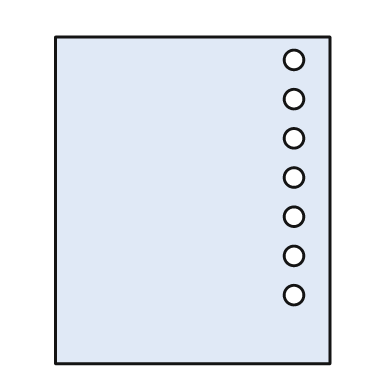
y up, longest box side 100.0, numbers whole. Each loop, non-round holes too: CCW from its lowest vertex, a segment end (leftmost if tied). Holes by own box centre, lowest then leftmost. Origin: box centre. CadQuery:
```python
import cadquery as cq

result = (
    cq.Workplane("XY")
    .moveTo(-42.0, -50.0)
    .lineTo(42.0, -50.0)
    .lineTo(42.0, 50.0)
    .lineTo(-42.0, 50.0)
    .close()
    .moveTo(31.0, -29.0)
    .circle(3.0)
    .moveTo(31.0, -17.0)
    .circle(3.0)
    .moveTo(31.0, -5.0)
    .circle(3.0)
    .moveTo(31.0, 7.0)
    .circle(3.0)
    .moveTo(31.0, 19.0)
    .circle(3.0)
    .moveTo(31.0, 31.0)
    .circle(3.0)
    .moveTo(31.0, 43.0)
    .circle(3.0)
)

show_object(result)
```